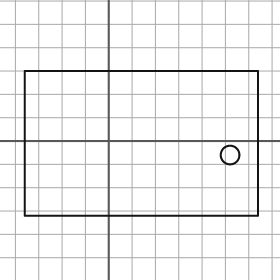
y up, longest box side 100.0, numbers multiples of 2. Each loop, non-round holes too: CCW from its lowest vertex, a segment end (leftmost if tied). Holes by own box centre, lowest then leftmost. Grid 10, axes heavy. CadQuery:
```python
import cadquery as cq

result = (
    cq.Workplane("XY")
    .moveTo(-36.0, -32.0)
    .lineTo(64.0, -32.0)
    .lineTo(64.0, 30.0)
    .lineTo(-36.0, 30.0)
    .close()
    .moveTo(52.0, -6.0)
    .circle(4.0)
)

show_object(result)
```